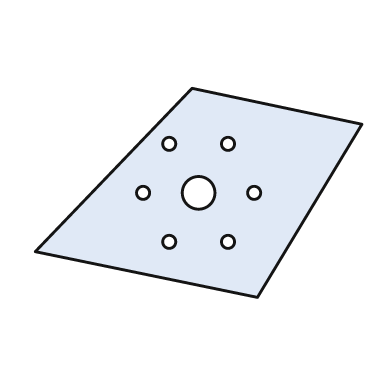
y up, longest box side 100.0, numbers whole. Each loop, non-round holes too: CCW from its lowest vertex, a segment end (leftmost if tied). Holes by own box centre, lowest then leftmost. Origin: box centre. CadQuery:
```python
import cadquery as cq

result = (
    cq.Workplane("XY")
    .moveTo(18.0, -32.0)
    .lineTo(50.0, 21.0)
    .lineTo(-2.0, 32.0)
    .lineTo(-50.0, -18.0)
    .close()
    .moveTo(-9.0, -15.0)
    .circle(2.0)
    .moveTo(9.0, -15.0)
    .circle(2.0)
    .moveTo(-17.0, 0.0)
    .circle(2.0)
    .moveTo(0.0, 0.0)
    .circle(5.0)
    .moveTo(17.0, 0.0)
    .circle(2.0)
    .moveTo(-9.0, 15.0)
    .circle(2.0)
    .moveTo(9.0, 15.0)
    .circle(2.0)
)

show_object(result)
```